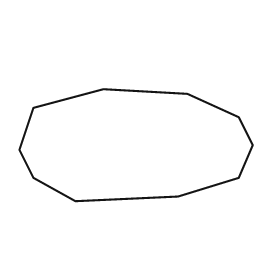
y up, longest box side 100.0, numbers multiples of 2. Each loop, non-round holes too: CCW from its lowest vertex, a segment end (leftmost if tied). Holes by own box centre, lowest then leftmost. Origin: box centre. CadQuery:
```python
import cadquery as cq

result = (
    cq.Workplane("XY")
    .moveTo(-26.0, -24.0)
    .lineTo(18.0, -22.0)
    .lineTo(44.0, -14.0)
    .lineTo(50.0, 0.0)
    .lineTo(44.0, 12.0)
    .lineTo(22.0, 22.0)
    .lineTo(-14.0, 24.0)
    .lineTo(-44.0, 16.0)
    .lineTo(-50.0, -2.0)
    .lineTo(-44.0, -14.0)
    .close()
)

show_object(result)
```